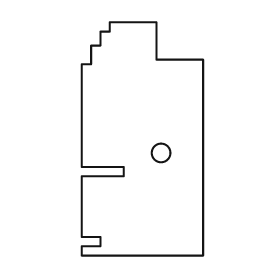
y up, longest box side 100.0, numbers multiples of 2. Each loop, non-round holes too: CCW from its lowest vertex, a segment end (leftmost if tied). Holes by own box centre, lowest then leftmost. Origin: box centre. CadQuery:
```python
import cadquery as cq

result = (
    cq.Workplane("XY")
    .moveTo(-26.0, -50.0)
    .lineTo(26.0, -50.0)
    .lineTo(26.0, 34.0)
    .lineTo(6.0, 34.0)
    .lineTo(6.0, 50.0)
    .lineTo(-14.0, 50.0)
    .lineTo(-14.0, 46.0)
    .lineTo(-18.0, 46.0)
    .lineTo(-18.0, 40.0)
    .lineTo(-22.0, 40.0)
    .lineTo(-22.0, 32.0)
    .lineTo(-26.0, 32.0)
    .lineTo(-26.0, -12.0)
    .lineTo(-8.0, -12.0)
    .lineTo(-8.0, -16.0)
    .lineTo(-26.0, -16.0)
    .lineTo(-26.0, -42.0)
    .lineTo(-18.0, -42.0)
    .lineTo(-18.0, -46.0)
    .lineTo(-26.0, -46.0)
    .close()
    .moveTo(8.0, -6.0)
    .circle(4.0)
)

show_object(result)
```